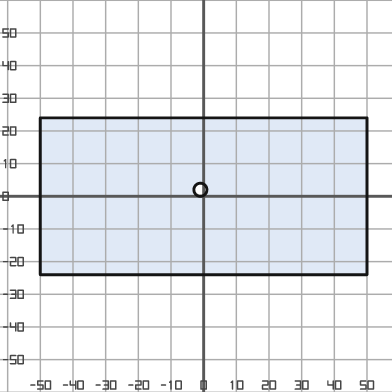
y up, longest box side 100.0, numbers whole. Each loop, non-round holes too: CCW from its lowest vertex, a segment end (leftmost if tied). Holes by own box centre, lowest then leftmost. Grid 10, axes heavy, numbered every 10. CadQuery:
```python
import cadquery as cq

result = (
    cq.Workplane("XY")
    .moveTo(-50.0, -24.0)
    .lineTo(50.0, -24.0)
    .lineTo(50.0, 24.0)
    .lineTo(-50.0, 24.0)
    .close()
    .moveTo(-1.0, 2.0)
    .circle(2.0)
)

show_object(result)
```